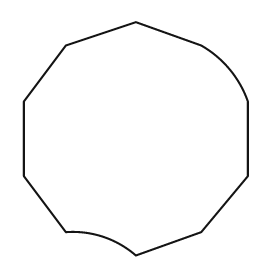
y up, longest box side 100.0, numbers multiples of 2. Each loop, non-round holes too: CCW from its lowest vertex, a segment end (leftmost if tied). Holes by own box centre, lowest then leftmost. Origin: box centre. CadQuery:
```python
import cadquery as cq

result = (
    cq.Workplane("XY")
    .moveTo(0.0, -50.0)
    .lineTo(28.0, -40.0)
    .lineTo(48.0, -16.0)
    .lineTo(48.0, 16.0)
    .threePointArc((40.0, 30.0), (28.0, 40.0))
    .lineTo(0.0, 50.0)
    .lineTo(-30.0, 40.0)
    .lineTo(-48.0, 16.0)
    .lineTo(-48.0, -16.0)
    .lineTo(-30.0, -40.0)
    .threePointArc((-14.0, -42.0), (0.0, -50.0))
    .close()
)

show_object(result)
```